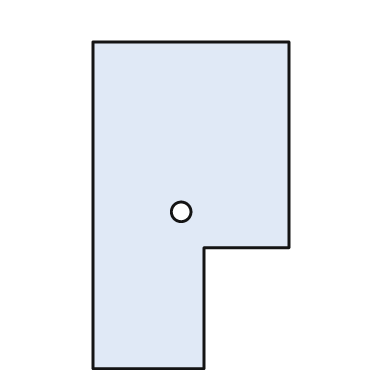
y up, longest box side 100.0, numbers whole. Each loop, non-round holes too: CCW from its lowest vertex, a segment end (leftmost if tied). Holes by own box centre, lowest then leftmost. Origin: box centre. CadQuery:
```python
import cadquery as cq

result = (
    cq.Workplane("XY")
    .moveTo(-30.0, -50.0)
    .lineTo(4.0, -50.0)
    .lineTo(4.0, -13.0)
    .lineTo(30.0, -13.0)
    .lineTo(30.0, 50.0)
    .lineTo(-30.0, 50.0)
    .close()
    .moveTo(-3.0, -2.0)
    .circle(3.0)
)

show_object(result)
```